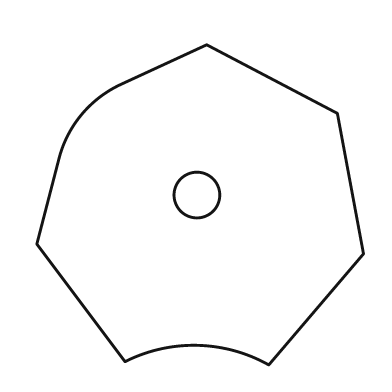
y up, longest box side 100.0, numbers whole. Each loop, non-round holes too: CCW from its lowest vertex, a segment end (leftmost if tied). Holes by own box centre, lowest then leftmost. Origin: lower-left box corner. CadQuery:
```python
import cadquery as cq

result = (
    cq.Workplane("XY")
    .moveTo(71.0, 0.0)
    .lineTo(100.0, 34.0)
    .lineTo(92.0, 77.0)
    .lineTo(52.0, 98.0)
    .lineTo(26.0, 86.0)
    .threePointArc((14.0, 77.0), (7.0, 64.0))
    .lineTo(0.0, 37.0)
    .lineTo(27.0, 1.0)
    .threePointArc((49.0, 6.0), (71.0, 0.0))
    .close()
    .moveTo(49.0, 52.0)
    .circle(7.0)
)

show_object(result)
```